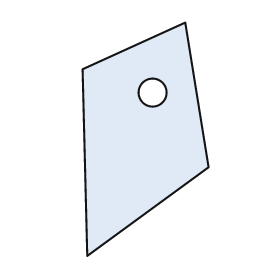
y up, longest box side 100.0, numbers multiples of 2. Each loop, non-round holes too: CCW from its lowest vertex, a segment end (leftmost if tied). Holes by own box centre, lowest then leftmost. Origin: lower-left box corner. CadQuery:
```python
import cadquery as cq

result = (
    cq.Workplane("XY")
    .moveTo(2.0, 0.0)
    .lineTo(54.0, 38.0)
    .lineTo(44.0, 100.0)
    .lineTo(0.0, 80.0)
    .close()
    .moveTo(30.0, 70.0)
    .circle(6.0)
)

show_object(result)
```